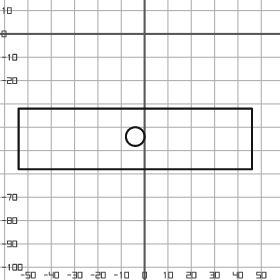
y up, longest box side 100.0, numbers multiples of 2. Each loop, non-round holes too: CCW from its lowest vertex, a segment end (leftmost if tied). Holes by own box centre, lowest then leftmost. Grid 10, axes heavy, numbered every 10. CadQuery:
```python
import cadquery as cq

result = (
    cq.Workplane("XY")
    .moveTo(-54.0, -58.0)
    .lineTo(46.0, -58.0)
    .lineTo(46.0, -32.0)
    .lineTo(-54.0, -32.0)
    .close()
    .moveTo(-4.0, -44.0)
    .circle(4.0)
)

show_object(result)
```